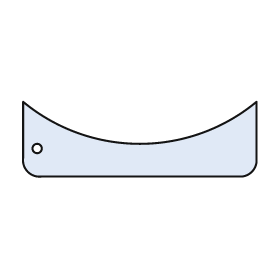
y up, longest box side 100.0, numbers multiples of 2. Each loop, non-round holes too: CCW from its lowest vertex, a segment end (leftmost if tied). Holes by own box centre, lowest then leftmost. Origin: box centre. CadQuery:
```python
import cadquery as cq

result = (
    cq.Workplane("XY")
    .moveTo(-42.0, -16.0)
    .lineTo(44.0, -16.0)
    .threePointArc((48.0, -14.0), (50.0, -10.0))
    .lineTo(50.0, 16.0)
    .threePointArc((0.0, -2.0), (-50.0, 16.0))
    .lineTo(-50.0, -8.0)
    .threePointArc((-48.0, -14.0), (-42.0, -16.0))
    .close()
    .moveTo(-44.0, -4.0)
    .circle(2.0)
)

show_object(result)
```